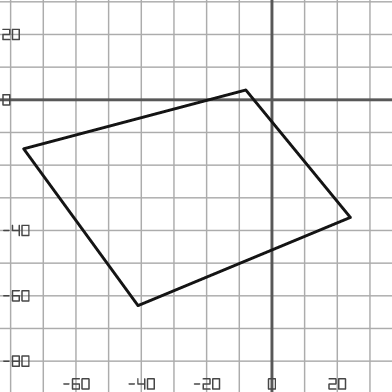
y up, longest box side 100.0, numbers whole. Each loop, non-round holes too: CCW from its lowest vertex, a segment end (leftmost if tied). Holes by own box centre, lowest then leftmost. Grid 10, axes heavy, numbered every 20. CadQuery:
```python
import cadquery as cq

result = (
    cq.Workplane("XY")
    .moveTo(-41.0, -63.0)
    .lineTo(24.0, -36.0)
    .lineTo(-8.0, 3.0)
    .lineTo(-76.0, -15.0)
    .close()
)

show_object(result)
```